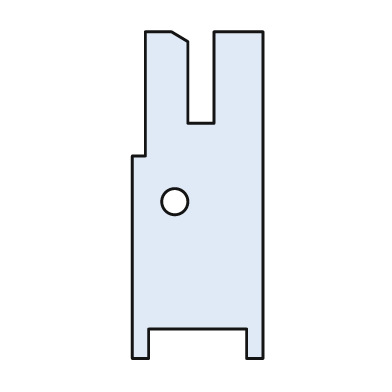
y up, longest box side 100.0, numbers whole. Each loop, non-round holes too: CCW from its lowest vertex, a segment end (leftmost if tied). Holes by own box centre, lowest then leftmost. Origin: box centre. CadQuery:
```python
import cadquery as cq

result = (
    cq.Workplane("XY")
    .moveTo(-20.0, -50.0)
    .lineTo(-15.0, -50.0)
    .lineTo(-15.0, -41.0)
    .lineTo(15.0, -41.0)
    .lineTo(15.0, -50.0)
    .lineTo(20.0, -50.0)
    .lineTo(20.0, 50.0)
    .lineTo(5.0, 50.0)
    .lineTo(5.0, 22.0)
    .lineTo(-3.0, 22.0)
    .lineTo(-3.0, 47.0)
    .lineTo(-8.0, 50.0)
    .lineTo(-16.0, 50.0)
    .lineTo(-16.0, 12.0)
    .lineTo(-20.0, 12.0)
    .close()
    .moveTo(-7.0, -2.0)
    .circle(4.0)
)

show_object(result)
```